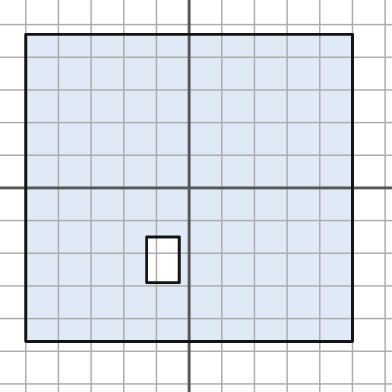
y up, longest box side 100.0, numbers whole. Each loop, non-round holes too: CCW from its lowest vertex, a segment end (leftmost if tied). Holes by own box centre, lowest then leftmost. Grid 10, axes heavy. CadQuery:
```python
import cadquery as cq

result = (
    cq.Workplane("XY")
    .moveTo(-50.0, -47.0)
    .lineTo(50.0, -47.0)
    .lineTo(50.0, 47.0)
    .lineTo(-50.0, 47.0)
    .close()
    .moveTo(-13.0, -29.0)
    .lineTo(-3.0, -29.0)
    .lineTo(-3.0, -15.0)
    .lineTo(-13.0, -15.0)
    .close()
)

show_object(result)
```